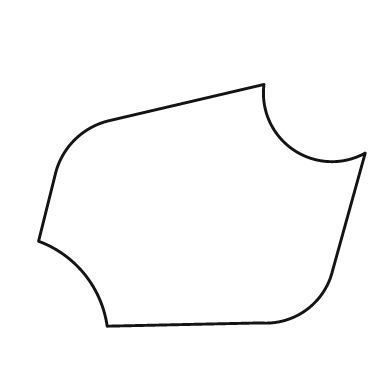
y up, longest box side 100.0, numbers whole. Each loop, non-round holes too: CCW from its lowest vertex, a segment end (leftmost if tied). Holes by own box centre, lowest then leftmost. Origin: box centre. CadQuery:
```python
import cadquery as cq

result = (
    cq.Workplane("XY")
    .moveTo(-29.0, -37.0)
    .lineTo(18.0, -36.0)
    .threePointArc((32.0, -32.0), (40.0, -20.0))
    .lineTo(50.0, 16.0)
    .threePointArc((28.0, 17.0), (19.0, 37.0))
    .lineTo(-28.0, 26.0)
    .threePointArc((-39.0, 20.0), (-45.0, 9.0))
    .lineTo(-50.0, -11.0)
    .threePointArc((-36.0, -21.0), (-29.0, -37.0))
    .close()
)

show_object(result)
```